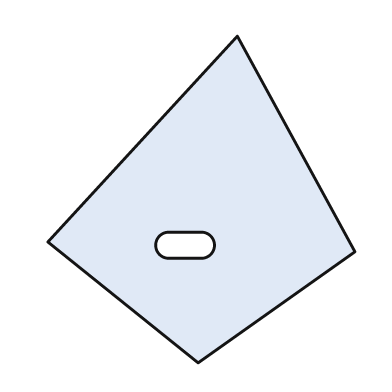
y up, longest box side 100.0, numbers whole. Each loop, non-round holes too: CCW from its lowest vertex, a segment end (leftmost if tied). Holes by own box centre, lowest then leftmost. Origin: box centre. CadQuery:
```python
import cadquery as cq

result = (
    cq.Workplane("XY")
    .moveTo(-1.0, -50.0)
    .lineTo(47.0, -16.0)
    .lineTo(11.0, 50.0)
    .lineTo(-47.0, -13.0)
    .close()
    .moveTo(-10.0, -18.0)
    .lineTo(0.0, -18.0)
    .threePointArc((4.0, -14.0), (0.0, -10.0))
    .lineTo(-10.0, -10.0)
    .threePointArc((-14.0, -14.0), (-10.0, -18.0))
    .close()
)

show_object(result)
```